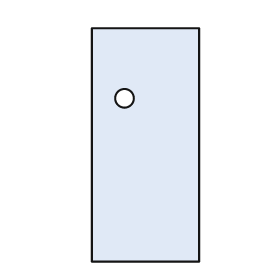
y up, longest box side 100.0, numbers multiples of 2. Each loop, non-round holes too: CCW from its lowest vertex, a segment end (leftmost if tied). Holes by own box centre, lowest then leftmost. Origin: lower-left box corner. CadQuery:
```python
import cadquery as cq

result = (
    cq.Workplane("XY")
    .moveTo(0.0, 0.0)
    .lineTo(46.0, 0.0)
    .lineTo(46.0, 100.0)
    .lineTo(0.0, 100.0)
    .close()
    .moveTo(14.0, 70.0)
    .circle(4.0)
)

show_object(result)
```